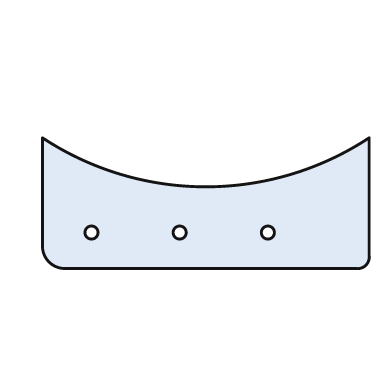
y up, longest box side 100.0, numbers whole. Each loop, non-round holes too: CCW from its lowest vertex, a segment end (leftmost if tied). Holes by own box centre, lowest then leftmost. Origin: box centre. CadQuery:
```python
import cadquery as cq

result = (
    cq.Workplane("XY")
    .moveTo(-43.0, -20.0)
    .lineTo(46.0, -20.0)
    .threePointArc((49.0, -19.0), (50.0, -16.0))
    .lineTo(50.0, 20.0)
    .threePointArc((0.0, 5.0), (-50.0, 20.0))
    .lineTo(-50.0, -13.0)
    .threePointArc((-48.0, -18.0), (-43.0, -20.0))
    .close()
    .moveTo(-35.0, -9.0)
    .circle(2.0)
    .moveTo(-8.0, -9.0)
    .circle(2.0)
    .moveTo(19.0, -9.0)
    .circle(2.0)
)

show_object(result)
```